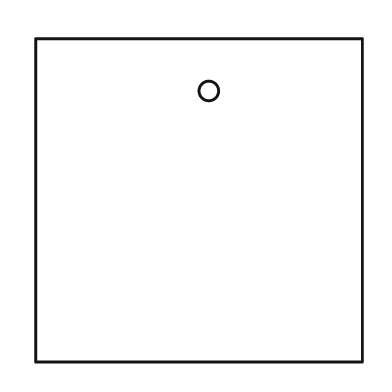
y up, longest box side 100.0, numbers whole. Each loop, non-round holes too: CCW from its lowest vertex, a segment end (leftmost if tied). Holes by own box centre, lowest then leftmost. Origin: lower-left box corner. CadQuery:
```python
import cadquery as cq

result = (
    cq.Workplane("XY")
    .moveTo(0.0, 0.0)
    .lineTo(100.0, 0.0)
    .lineTo(100.0, 99.0)
    .lineTo(0.0, 99.0)
    .close()
    .moveTo(53.0, 83.0)
    .circle(3.0)
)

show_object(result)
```